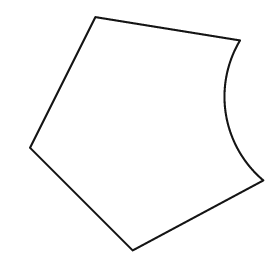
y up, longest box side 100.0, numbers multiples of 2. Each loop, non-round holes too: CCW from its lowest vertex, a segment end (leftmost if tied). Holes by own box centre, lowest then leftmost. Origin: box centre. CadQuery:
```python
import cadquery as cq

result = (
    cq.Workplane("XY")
    .moveTo(-6.0, -50.0)
    .lineTo(50.0, -20.0)
    .threePointArc((34.0, 8.0), (40.0, 40.0))
    .lineTo(-22.0, 50.0)
    .lineTo(-50.0, -6.0)
    .close()
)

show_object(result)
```